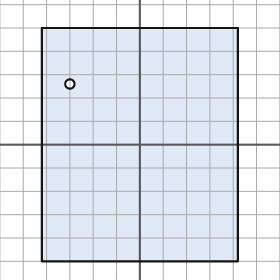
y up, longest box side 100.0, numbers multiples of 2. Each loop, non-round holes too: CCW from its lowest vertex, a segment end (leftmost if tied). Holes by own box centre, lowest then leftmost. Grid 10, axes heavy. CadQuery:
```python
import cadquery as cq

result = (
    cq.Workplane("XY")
    .moveTo(-42.0, -50.0)
    .lineTo(42.0, -50.0)
    .lineTo(42.0, 50.0)
    .lineTo(-42.0, 50.0)
    .close()
    .moveTo(-30.0, 26.0)
    .circle(2.0)
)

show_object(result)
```